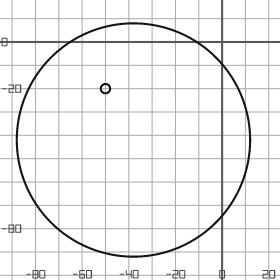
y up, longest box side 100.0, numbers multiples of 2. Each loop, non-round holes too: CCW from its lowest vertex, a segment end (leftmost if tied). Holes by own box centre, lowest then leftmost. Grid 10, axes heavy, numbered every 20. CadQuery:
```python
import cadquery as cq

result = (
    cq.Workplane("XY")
    .moveTo(-38.0, -42.0)
    .circle(50.0)
    .moveTo(-50.0, -20.0)
    .circle(2.0)
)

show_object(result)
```